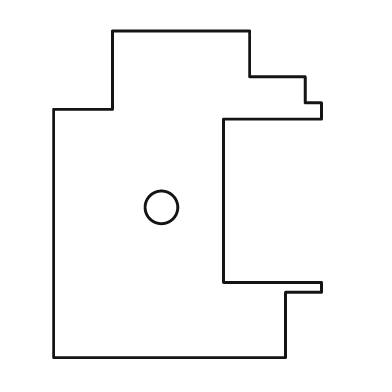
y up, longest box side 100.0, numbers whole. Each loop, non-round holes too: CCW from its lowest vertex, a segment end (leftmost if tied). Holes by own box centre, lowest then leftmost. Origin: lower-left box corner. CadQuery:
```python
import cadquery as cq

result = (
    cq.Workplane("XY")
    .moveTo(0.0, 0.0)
    .lineTo(71.0, 0.0)
    .lineTo(71.0, 20.0)
    .lineTo(82.0, 20.0)
    .lineTo(82.0, 23.0)
    .lineTo(52.0, 23.0)
    .lineTo(52.0, 73.0)
    .lineTo(82.0, 73.0)
    .lineTo(82.0, 78.0)
    .lineTo(77.0, 78.0)
    .lineTo(77.0, 86.0)
    .lineTo(60.0, 86.0)
    .lineTo(60.0, 100.0)
    .lineTo(18.0, 100.0)
    .lineTo(18.0, 76.0)
    .lineTo(0.0, 76.0)
    .close()
    .moveTo(33.0, 46.0)
    .circle(5.0)
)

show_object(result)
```